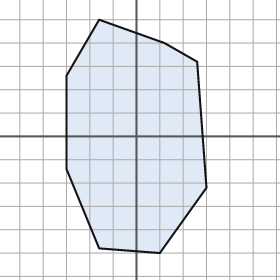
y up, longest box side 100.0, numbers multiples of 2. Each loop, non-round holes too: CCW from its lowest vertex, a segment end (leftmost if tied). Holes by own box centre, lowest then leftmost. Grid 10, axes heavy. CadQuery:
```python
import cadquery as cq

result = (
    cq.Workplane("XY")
    .moveTo(10.0, -50.0)
    .lineTo(30.0, -22.0)
    .lineTo(26.0, 32.0)
    .lineTo(12.0, 40.0)
    .lineTo(-16.0, 50.0)
    .lineTo(-30.0, 26.0)
    .lineTo(-30.0, -14.0)
    .lineTo(-16.0, -48.0)
    .close()
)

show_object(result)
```